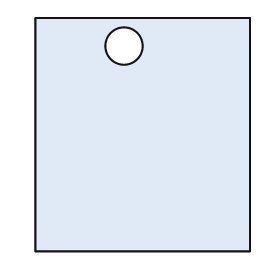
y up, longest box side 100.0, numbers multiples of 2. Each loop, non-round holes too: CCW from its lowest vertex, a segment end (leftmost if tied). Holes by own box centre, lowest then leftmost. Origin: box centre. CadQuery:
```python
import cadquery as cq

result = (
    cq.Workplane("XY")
    .moveTo(-46.0, -50.0)
    .lineTo(46.0, -50.0)
    .lineTo(46.0, 50.0)
    .lineTo(-46.0, 50.0)
    .close()
    .moveTo(-8.0, 38.0)
    .circle(8.0)
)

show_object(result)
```